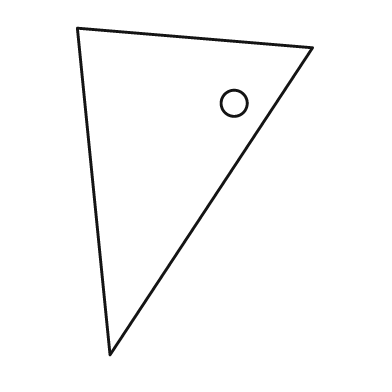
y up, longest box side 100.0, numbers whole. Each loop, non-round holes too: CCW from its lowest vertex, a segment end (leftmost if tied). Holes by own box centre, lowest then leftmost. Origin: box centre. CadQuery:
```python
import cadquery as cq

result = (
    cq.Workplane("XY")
    .moveTo(-26.0, -50.0)
    .lineTo(36.0, 44.0)
    .lineTo(-36.0, 50.0)
    .close()
    .moveTo(12.0, 27.0)
    .circle(4.0)
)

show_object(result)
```